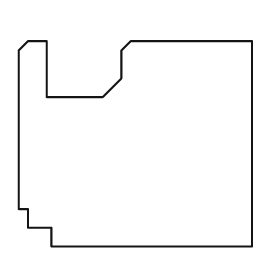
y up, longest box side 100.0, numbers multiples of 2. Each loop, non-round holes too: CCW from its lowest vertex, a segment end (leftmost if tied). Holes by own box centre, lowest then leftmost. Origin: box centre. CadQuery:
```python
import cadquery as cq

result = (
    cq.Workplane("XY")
    .moveTo(-36.0, -44.0)
    .lineTo(50.0, -44.0)
    .lineTo(50.0, 44.0)
    .lineTo(-2.0, 44.0)
    .lineTo(-6.0, 40.0)
    .lineTo(-6.0, 28.0)
    .lineTo(-14.0, 20.0)
    .lineTo(-38.0, 20.0)
    .lineTo(-38.0, 44.0)
    .lineTo(-46.0, 44.0)
    .lineTo(-50.0, 40.0)
    .lineTo(-50.0, -28.0)
    .lineTo(-46.0, -28.0)
    .lineTo(-46.0, -36.0)
    .lineTo(-36.0, -36.0)
    .close()
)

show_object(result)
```